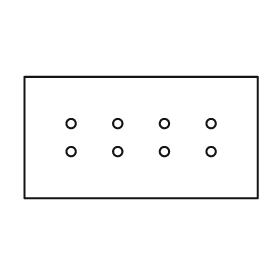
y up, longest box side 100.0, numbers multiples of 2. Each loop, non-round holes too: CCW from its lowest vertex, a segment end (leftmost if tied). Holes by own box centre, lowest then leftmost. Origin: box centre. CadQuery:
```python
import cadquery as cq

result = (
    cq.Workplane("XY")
    .moveTo(-50.0, -26.0)
    .lineTo(50.0, -26.0)
    .lineTo(50.0, 26.0)
    .lineTo(-50.0, 26.0)
    .close()
    .moveTo(-30.0, -6.0)
    .circle(2.0)
    .moveTo(-10.0, -6.0)
    .circle(2.0)
    .moveTo(10.0, -6.0)
    .circle(2.0)
    .moveTo(30.0, -6.0)
    .circle(2.0)
    .moveTo(-30.0, 6.0)
    .circle(2.0)
    .moveTo(-10.0, 6.0)
    .circle(2.0)
    .moveTo(10.0, 6.0)
    .circle(2.0)
    .moveTo(30.0, 6.0)
    .circle(2.0)
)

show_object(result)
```